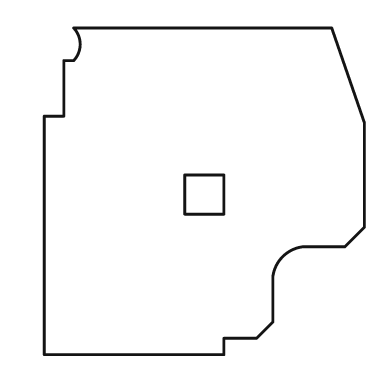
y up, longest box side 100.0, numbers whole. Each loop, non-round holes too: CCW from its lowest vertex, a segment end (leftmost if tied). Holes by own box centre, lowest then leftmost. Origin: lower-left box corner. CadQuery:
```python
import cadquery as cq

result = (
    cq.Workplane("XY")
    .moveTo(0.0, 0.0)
    .lineTo(55.0, 0.0)
    .lineTo(55.0, 5.0)
    .lineTo(65.0, 5.0)
    .lineTo(70.0, 10.0)
    .lineTo(70.0, 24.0)
    .threePointArc((73.0, 30.0), (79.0, 33.0))
    .lineTo(92.0, 33.0)
    .lineTo(98.0, 39.0)
    .lineTo(98.0, 71.0)
    .lineTo(88.0, 100.0)
    .lineTo(9.0, 100.0)
    .threePointArc((11.0, 95.0), (9.0, 90.0))
    .lineTo(6.0, 90.0)
    .lineTo(6.0, 73.0)
    .lineTo(0.0, 73.0)
    .close()
    .moveTo(43.0, 43.0)
    .lineTo(55.0, 43.0)
    .lineTo(55.0, 55.0)
    .lineTo(43.0, 55.0)
    .close()
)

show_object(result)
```